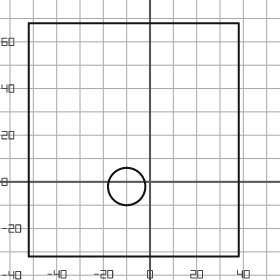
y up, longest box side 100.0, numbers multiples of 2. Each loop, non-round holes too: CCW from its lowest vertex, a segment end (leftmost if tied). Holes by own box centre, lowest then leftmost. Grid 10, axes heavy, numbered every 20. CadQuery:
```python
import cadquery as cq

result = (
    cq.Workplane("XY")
    .moveTo(-52.0, -32.0)
    .lineTo(38.0, -32.0)
    .lineTo(38.0, 68.0)
    .lineTo(-52.0, 68.0)
    .close()
    .moveTo(-10.0, -2.0)
    .circle(8.0)
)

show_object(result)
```